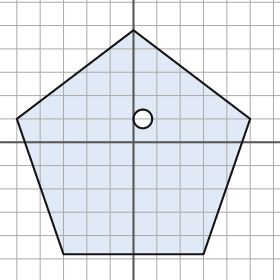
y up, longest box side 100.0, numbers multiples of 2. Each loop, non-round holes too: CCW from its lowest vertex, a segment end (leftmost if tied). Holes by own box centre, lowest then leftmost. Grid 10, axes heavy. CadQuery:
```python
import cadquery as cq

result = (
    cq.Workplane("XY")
    .moveTo(-30.0, -48.0)
    .lineTo(30.0, -48.0)
    .lineTo(50.0, 10.0)
    .lineTo(0.0, 48.0)
    .lineTo(-50.0, 10.0)
    .close()
    .moveTo(4.0, 10.0)
    .circle(4.0)
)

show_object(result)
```